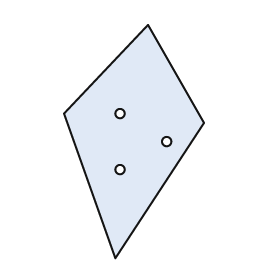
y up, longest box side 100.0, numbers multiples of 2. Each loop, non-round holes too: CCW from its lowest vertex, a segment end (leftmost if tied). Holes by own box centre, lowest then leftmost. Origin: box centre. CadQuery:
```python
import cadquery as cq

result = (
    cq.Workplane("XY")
    .moveTo(-8.0, -50.0)
    .lineTo(30.0, 8.0)
    .lineTo(6.0, 50.0)
    .lineTo(-30.0, 12.0)
    .close()
    .moveTo(-6.0, -12.0)
    .circle(2.0)
    .moveTo(14.0, 0.0)
    .circle(2.0)
    .moveTo(-6.0, 12.0)
    .circle(2.0)
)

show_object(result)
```